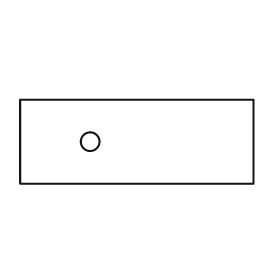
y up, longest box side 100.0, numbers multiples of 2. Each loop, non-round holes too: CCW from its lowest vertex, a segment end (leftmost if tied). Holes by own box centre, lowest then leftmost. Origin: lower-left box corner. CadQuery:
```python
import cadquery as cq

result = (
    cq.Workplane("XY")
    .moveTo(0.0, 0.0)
    .lineTo(100.0, 0.0)
    .lineTo(100.0, 36.0)
    .lineTo(0.0, 36.0)
    .close()
    .moveTo(30.0, 18.0)
    .circle(4.0)
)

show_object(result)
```